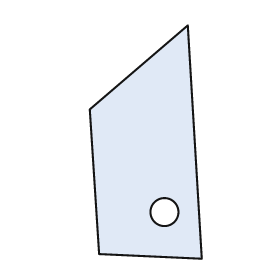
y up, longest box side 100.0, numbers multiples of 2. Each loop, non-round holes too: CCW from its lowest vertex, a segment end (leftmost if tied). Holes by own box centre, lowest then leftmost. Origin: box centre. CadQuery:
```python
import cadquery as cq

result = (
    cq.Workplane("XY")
    .moveTo(24.0, -50.0)
    .lineTo(18.0, 50.0)
    .lineTo(-24.0, 14.0)
    .lineTo(-20.0, -48.0)
    .close()
    .moveTo(8.0, -30.0)
    .circle(6.0)
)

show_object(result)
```